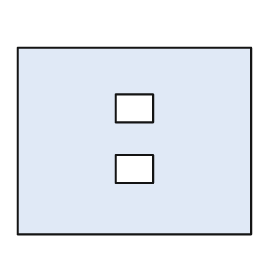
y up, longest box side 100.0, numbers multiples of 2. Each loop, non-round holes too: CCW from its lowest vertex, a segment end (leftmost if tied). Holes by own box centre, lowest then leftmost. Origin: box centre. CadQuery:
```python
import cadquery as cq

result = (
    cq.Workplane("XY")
    .moveTo(-50.0, -40.0)
    .lineTo(50.0, -40.0)
    .lineTo(50.0, 40.0)
    .lineTo(-50.0, 40.0)
    .close()
    .moveTo(-8.0, -18.0)
    .lineTo(8.0, -18.0)
    .lineTo(8.0, -6.0)
    .lineTo(-8.0, -6.0)
    .close()
    .moveTo(-8.0, 8.0)
    .lineTo(8.0, 8.0)
    .lineTo(8.0, 20.0)
    .lineTo(-8.0, 20.0)
    .close()
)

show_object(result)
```